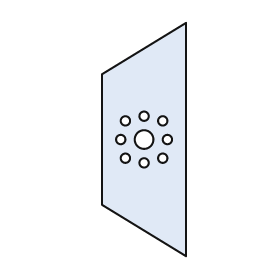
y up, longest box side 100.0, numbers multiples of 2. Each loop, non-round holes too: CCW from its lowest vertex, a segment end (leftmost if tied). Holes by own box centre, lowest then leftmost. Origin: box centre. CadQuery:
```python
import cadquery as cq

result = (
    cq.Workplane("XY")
    .moveTo(18.0, -50.0)
    .lineTo(18.0, 50.0)
    .lineTo(-18.0, 28.0)
    .lineTo(-18.0, -28.0)
    .close()
    .moveTo(0.0, -10.0)
    .circle(2.0)
    .moveTo(-8.0, -8.0)
    .circle(2.0)
    .moveTo(8.0, -8.0)
    .circle(2.0)
    .moveTo(-10.0, 0.0)
    .circle(2.0)
    .moveTo(0.0, 0.0)
    .circle(4.0)
    .moveTo(10.0, 0.0)
    .circle(2.0)
    .moveTo(-8.0, 8.0)
    .circle(2.0)
    .moveTo(8.0, 8.0)
    .circle(2.0)
    .moveTo(0.0, 10.0)
    .circle(2.0)
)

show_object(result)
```